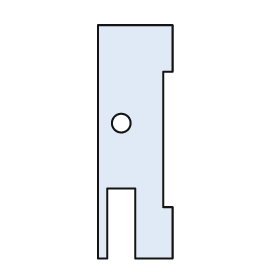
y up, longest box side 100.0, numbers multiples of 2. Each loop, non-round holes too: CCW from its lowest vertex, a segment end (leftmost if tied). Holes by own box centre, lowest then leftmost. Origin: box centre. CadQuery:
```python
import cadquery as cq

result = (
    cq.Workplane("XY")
    .moveTo(-16.0, -50.0)
    .lineTo(-12.0, -50.0)
    .lineTo(-12.0, -20.0)
    .lineTo(0.0, -20.0)
    .lineTo(0.0, -50.0)
    .lineTo(16.0, -50.0)
    .lineTo(16.0, -28.0)
    .lineTo(12.0, -28.0)
    .lineTo(12.0, 30.0)
    .lineTo(16.0, 30.0)
    .lineTo(16.0, 50.0)
    .lineTo(-16.0, 50.0)
    .close()
    .moveTo(-6.0, 8.0)
    .circle(4.0)
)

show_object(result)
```